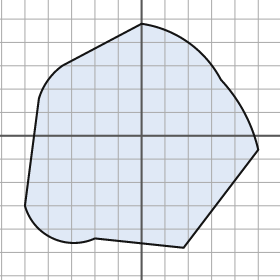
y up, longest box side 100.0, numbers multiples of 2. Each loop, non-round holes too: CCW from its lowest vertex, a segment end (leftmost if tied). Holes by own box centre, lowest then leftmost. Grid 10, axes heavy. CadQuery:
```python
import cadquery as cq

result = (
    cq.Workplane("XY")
    .moveTo(18.0, -48.0)
    .lineTo(50.0, -6.0)
    .threePointArc((44.0, 10.0), (34.0, 24.0))
    .threePointArc((20.0, 40.0), (0.0, 48.0))
    .lineTo(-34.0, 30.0)
    .threePointArc((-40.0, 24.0), (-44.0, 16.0))
    .lineTo(-50.0, -30.0)
    .threePointArc((-38.0, -44.0), (-20.0, -44.0))
    .close()
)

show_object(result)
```